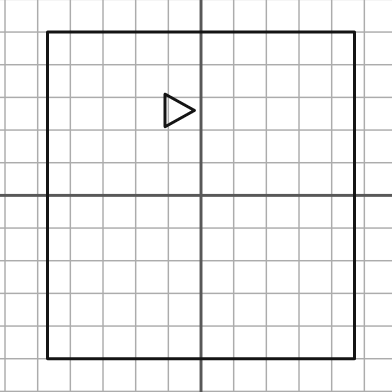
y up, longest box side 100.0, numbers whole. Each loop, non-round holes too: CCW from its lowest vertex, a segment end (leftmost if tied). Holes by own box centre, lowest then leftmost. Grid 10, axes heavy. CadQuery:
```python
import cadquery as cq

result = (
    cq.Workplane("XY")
    .moveTo(-47.0, -50.0)
    .lineTo(47.0, -50.0)
    .lineTo(47.0, 50.0)
    .lineTo(-47.0, 50.0)
    .close()
    .moveTo(-11.0, 21.0)
    .lineTo(-2.0, 26.0)
    .lineTo(-11.0, 31.0)
    .close()
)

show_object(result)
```